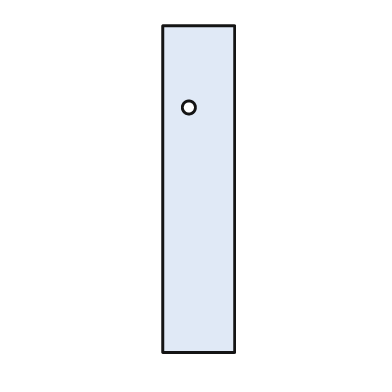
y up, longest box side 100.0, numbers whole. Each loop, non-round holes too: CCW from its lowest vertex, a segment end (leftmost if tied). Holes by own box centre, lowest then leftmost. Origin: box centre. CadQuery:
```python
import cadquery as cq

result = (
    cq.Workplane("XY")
    .moveTo(-11.0, -50.0)
    .lineTo(11.0, -50.0)
    .lineTo(11.0, 50.0)
    .lineTo(-11.0, 50.0)
    .close()
    .moveTo(-3.0, 25.0)
    .circle(2.0)
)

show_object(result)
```